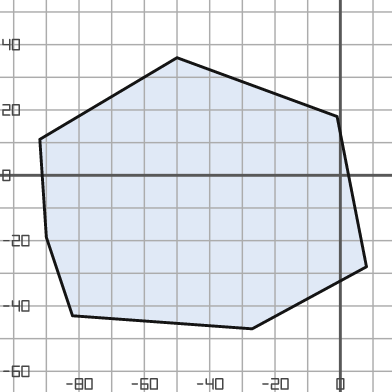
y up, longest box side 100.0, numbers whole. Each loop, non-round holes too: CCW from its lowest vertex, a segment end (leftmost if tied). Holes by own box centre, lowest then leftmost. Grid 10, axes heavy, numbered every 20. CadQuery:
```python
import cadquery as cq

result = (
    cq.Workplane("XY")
    .moveTo(-27.0, -47.0)
    .lineTo(8.0, -28.0)
    .lineTo(-1.0, 18.0)
    .lineTo(-50.0, 36.0)
    .lineTo(-92.0, 11.0)
    .lineTo(-90.0, -19.0)
    .lineTo(-82.0, -43.0)
    .close()
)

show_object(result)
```